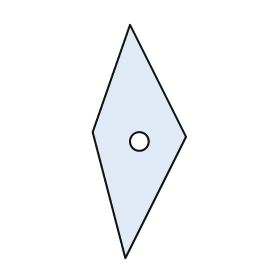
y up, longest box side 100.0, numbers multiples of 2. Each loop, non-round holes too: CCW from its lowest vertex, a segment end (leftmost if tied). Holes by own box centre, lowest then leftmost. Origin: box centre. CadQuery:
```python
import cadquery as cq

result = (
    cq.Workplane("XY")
    .moveTo(-6.0, -50.0)
    .lineTo(20.0, 2.0)
    .lineTo(-4.0, 50.0)
    .lineTo(-20.0, 4.0)
    .close()
    .moveTo(0.0, 0.0)
    .circle(4.0)
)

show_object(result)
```